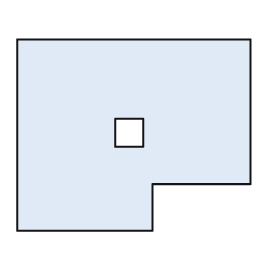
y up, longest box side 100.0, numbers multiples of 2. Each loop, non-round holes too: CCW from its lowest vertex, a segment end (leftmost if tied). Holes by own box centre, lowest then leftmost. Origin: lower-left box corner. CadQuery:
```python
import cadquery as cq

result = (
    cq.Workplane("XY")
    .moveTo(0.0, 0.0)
    .lineTo(58.0, 0.0)
    .lineTo(58.0, 20.0)
    .lineTo(100.0, 20.0)
    .lineTo(100.0, 82.0)
    .lineTo(0.0, 82.0)
    .close()
    .moveTo(42.0, 36.0)
    .lineTo(54.0, 36.0)
    .lineTo(54.0, 48.0)
    .lineTo(42.0, 48.0)
    .close()
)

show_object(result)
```